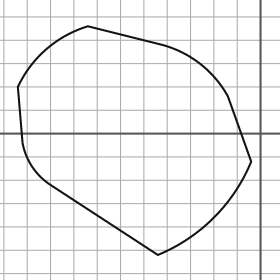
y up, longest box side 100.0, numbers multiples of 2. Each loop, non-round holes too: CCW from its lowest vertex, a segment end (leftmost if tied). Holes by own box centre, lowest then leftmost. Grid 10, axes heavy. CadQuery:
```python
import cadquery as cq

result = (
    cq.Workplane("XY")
    .moveTo(-44.0, -52.0)
    .threePointArc((-20.0, -36.0), (-4.0, -12.0))
    .lineTo(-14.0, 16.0)
    .threePointArc((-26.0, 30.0), (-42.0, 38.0))
    .lineTo(-74.0, 46.0)
    .threePointArc((-92.0, 36.0), (-104.0, 20.0))
    .lineTo(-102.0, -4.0)
    .threePointArc((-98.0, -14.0), (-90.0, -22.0))
    .close()
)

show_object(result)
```